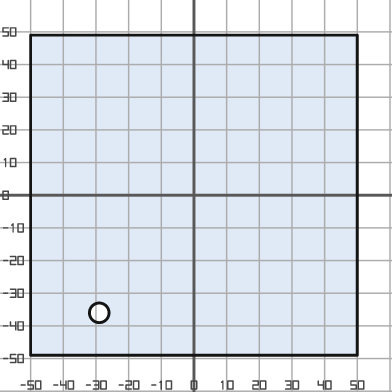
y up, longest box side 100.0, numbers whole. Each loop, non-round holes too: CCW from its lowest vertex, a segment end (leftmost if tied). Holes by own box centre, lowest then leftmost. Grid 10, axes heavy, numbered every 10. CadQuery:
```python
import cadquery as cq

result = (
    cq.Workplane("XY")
    .moveTo(-50.0, -49.0)
    .lineTo(50.0, -49.0)
    .lineTo(50.0, 49.0)
    .lineTo(-50.0, 49.0)
    .close()
    .moveTo(-29.0, -36.0)
    .circle(3.0)
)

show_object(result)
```